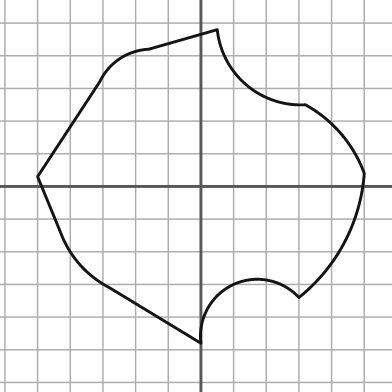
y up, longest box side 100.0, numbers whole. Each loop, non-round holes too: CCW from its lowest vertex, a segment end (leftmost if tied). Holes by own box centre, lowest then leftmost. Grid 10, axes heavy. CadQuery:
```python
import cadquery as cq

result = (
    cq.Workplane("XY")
    .moveTo(0.0, -48.0)
    .threePointArc((10.0, -30.0), (30.0, -34.0))
    .threePointArc((44.0, -17.0), (50.0, 4.0))
    .threePointArc((43.0, 16.0), (32.0, 25.0))
    .threePointArc((14.0, 31.0), (5.0, 48.0))
    .lineTo(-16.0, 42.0)
    .threePointArc((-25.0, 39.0), (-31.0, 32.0))
    .lineTo(-50.0, 3.0)
    .lineTo(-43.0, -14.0)
    .threePointArc((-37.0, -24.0), (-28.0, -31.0))
    .close()
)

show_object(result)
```